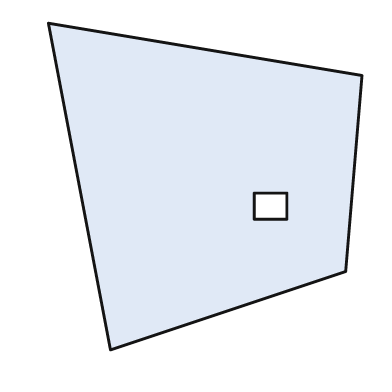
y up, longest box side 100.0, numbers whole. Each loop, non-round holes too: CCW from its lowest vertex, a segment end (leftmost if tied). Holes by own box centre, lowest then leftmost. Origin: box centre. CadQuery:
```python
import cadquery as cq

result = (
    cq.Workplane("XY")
    .moveTo(-29.0, -50.0)
    .lineTo(43.0, -26.0)
    .lineTo(48.0, 34.0)
    .lineTo(-48.0, 50.0)
    .close()
    .moveTo(15.0, -10.0)
    .lineTo(25.0, -10.0)
    .lineTo(25.0, -2.0)
    .lineTo(15.0, -2.0)
    .close()
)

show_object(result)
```